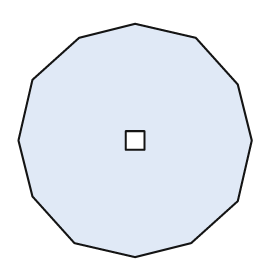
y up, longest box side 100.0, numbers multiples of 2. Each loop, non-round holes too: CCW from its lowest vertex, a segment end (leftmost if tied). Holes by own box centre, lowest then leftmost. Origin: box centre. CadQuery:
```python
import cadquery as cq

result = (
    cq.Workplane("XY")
    .moveTo(0.0, -50.0)
    .lineTo(24.0, -44.0)
    .lineTo(44.0, -26.0)
    .lineTo(50.0, 0.0)
    .lineTo(44.0, 24.0)
    .lineTo(26.0, 44.0)
    .lineTo(0.0, 50.0)
    .lineTo(-24.0, 44.0)
    .lineTo(-44.0, 26.0)
    .lineTo(-50.0, 0.0)
    .lineTo(-44.0, -24.0)
    .lineTo(-26.0, -44.0)
    .close()
    .moveTo(-4.0, -4.0)
    .lineTo(4.0, -4.0)
    .lineTo(4.0, 4.0)
    .lineTo(-4.0, 4.0)
    .close()
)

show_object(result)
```